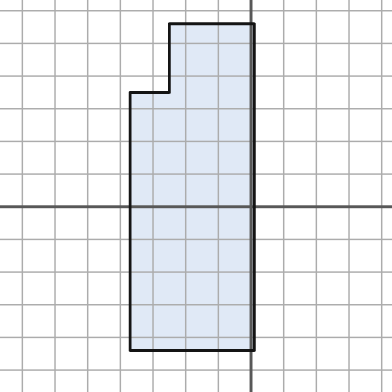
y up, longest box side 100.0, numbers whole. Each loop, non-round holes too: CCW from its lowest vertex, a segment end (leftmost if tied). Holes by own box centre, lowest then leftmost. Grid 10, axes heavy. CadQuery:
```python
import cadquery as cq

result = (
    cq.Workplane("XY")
    .moveTo(-37.0, -44.0)
    .lineTo(1.0, -44.0)
    .lineTo(1.0, 56.0)
    .lineTo(-25.0, 56.0)
    .lineTo(-25.0, 35.0)
    .lineTo(-37.0, 35.0)
    .close()
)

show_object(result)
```